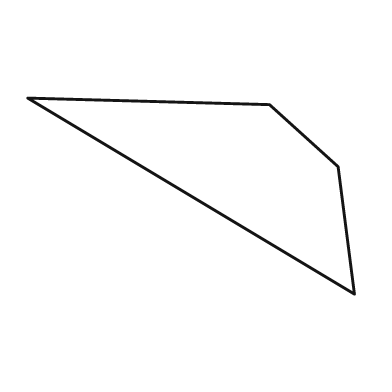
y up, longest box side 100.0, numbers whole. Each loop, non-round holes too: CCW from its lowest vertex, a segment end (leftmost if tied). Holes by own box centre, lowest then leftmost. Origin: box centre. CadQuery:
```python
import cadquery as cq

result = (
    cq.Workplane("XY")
    .moveTo(50.0, -30.0)
    .lineTo(45.0, 9.0)
    .lineTo(24.0, 28.0)
    .lineTo(-50.0, 30.0)
    .close()
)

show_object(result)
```